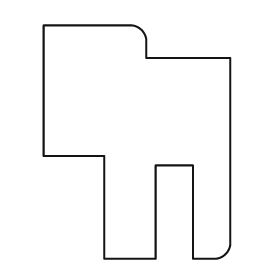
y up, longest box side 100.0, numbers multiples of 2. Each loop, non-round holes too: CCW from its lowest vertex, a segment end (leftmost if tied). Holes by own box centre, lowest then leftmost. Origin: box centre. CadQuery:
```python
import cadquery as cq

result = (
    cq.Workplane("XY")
    .moveTo(-14.0, -50.0)
    .lineTo(8.0, -50.0)
    .lineTo(8.0, -10.0)
    .lineTo(24.0, -10.0)
    .lineTo(24.0, -50.0)
    .lineTo(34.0, -50.0)
    .threePointArc((38.0, -48.0), (40.0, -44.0))
    .lineTo(40.0, 36.0)
    .lineTo(4.0, 36.0)
    .lineTo(4.0, 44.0)
    .threePointArc((2.0, 48.0), (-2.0, 50.0))
    .lineTo(-40.0, 50.0)
    .lineTo(-40.0, -6.0)
    .lineTo(-14.0, -6.0)
    .close()
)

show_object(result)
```